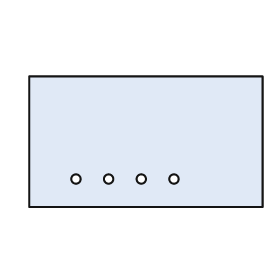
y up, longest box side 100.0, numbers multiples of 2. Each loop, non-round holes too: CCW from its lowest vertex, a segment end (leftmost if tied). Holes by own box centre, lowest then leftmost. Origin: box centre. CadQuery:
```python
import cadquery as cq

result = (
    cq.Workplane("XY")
    .moveTo(-50.0, -28.0)
    .lineTo(50.0, -28.0)
    .lineTo(50.0, 28.0)
    .lineTo(-50.0, 28.0)
    .close()
    .moveTo(-30.0, -16.0)
    .circle(2.0)
    .moveTo(-16.0, -16.0)
    .circle(2.0)
    .moveTo(-2.0, -16.0)
    .circle(2.0)
    .moveTo(12.0, -16.0)
    .circle(2.0)
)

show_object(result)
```